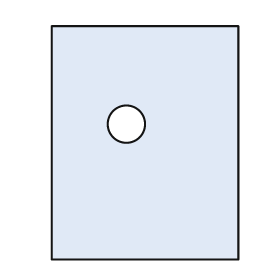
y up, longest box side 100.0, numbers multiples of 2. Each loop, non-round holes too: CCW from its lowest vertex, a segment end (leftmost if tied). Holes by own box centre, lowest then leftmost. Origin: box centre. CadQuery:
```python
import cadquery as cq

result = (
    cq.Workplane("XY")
    .moveTo(-40.0, -50.0)
    .lineTo(40.0, -50.0)
    .lineTo(40.0, 50.0)
    .lineTo(-40.0, 50.0)
    .close()
    .moveTo(-8.0, 8.0)
    .circle(8.0)
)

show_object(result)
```